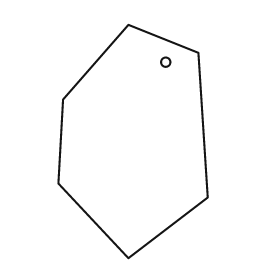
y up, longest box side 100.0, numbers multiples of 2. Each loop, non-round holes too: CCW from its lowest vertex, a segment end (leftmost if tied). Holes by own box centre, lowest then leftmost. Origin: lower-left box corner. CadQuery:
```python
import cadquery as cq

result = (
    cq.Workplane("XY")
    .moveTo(30.0, 0.0)
    .lineTo(64.0, 26.0)
    .lineTo(60.0, 88.0)
    .lineTo(30.0, 100.0)
    .lineTo(2.0, 68.0)
    .lineTo(0.0, 32.0)
    .close()
    .moveTo(46.0, 84.0)
    .circle(2.0)
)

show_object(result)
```